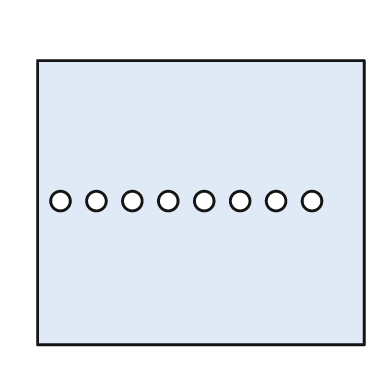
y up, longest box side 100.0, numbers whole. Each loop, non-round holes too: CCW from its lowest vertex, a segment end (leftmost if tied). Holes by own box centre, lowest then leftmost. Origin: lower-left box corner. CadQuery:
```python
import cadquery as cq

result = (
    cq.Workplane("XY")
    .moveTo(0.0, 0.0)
    .lineTo(100.0, 0.0)
    .lineTo(100.0, 87.0)
    .lineTo(0.0, 87.0)
    .close()
    .moveTo(7.0, 44.0)
    .circle(3.0)
    .moveTo(18.0, 44.0)
    .circle(3.0)
    .moveTo(29.0, 44.0)
    .circle(3.0)
    .moveTo(40.0, 44.0)
    .circle(3.0)
    .moveTo(51.0, 44.0)
    .circle(3.0)
    .moveTo(62.0, 44.0)
    .circle(3.0)
    .moveTo(73.0, 44.0)
    .circle(3.0)
    .moveTo(84.0, 44.0)
    .circle(3.0)
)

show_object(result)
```